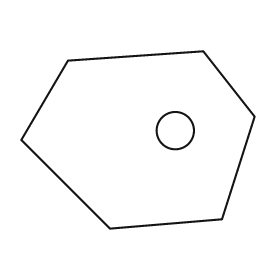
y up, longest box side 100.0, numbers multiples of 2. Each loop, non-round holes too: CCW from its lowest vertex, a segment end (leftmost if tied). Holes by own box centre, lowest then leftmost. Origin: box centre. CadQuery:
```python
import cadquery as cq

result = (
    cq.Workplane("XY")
    .moveTo(-12.0, -38.0)
    .lineTo(36.0, -34.0)
    .lineTo(50.0, 10.0)
    .lineTo(28.0, 38.0)
    .lineTo(-30.0, 34.0)
    .lineTo(-50.0, 0.0)
    .close()
    .moveTo(16.0, 4.0)
    .circle(8.0)
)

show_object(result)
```